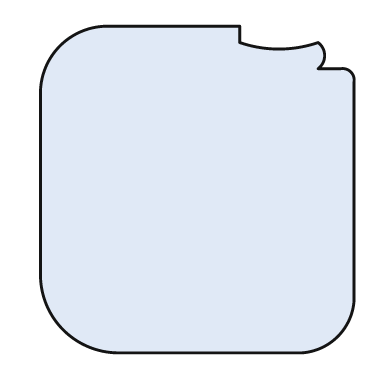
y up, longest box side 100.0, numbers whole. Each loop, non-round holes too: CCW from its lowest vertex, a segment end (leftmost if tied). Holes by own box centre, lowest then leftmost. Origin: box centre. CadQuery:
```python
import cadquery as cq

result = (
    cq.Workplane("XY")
    .moveTo(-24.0, -50.0)
    .lineTo(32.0, -50.0)
    .threePointArc((43.0, -45.0), (48.0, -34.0))
    .lineTo(48.0, 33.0)
    .threePointArc((47.0, 36.0), (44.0, 37.0))
    .lineTo(37.0, 37.0)
    .threePointArc((39.0, 41.0), (37.0, 45.0))
    .threePointArc((25.0, 43.0), (13.0, 45.0))
    .lineTo(13.0, 50.0)
    .lineTo(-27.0, 50.0)
    .threePointArc((-42.0, 44.0), (-48.0, 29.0))
    .lineTo(-48.0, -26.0)
    .threePointArc((-41.0, -43.0), (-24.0, -50.0))
    .close()
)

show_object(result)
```